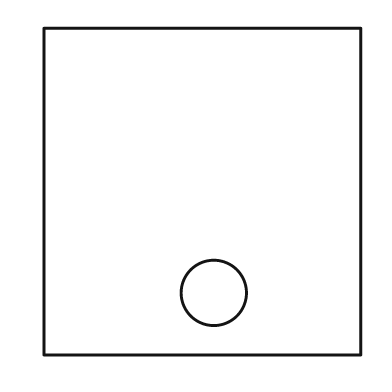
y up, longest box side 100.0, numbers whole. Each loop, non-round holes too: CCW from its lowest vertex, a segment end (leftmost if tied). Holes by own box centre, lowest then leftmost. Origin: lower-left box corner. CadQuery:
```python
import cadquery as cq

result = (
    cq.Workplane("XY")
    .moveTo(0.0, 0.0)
    .lineTo(97.0, 0.0)
    .lineTo(97.0, 100.0)
    .lineTo(0.0, 100.0)
    .close()
    .moveTo(52.0, 19.0)
    .circle(10.0)
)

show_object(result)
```